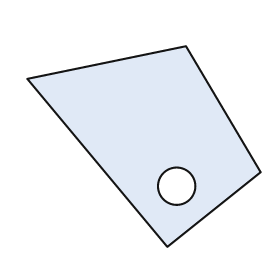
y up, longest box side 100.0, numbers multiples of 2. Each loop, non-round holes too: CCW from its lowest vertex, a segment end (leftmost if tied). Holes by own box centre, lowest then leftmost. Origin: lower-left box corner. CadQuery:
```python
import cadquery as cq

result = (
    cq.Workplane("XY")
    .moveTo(60.0, 0.0)
    .lineTo(100.0, 32.0)
    .lineTo(68.0, 86.0)
    .lineTo(0.0, 72.0)
    .close()
    .moveTo(64.0, 26.0)
    .circle(8.0)
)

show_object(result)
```